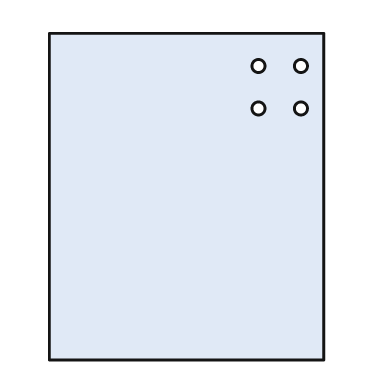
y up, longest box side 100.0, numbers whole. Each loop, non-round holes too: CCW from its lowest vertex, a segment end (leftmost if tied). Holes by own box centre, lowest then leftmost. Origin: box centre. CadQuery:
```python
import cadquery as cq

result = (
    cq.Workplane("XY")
    .moveTo(-42.0, -50.0)
    .lineTo(42.0, -50.0)
    .lineTo(42.0, 50.0)
    .lineTo(-42.0, 50.0)
    .close()
    .moveTo(22.0, 27.0)
    .circle(2.0)
    .moveTo(35.0, 27.0)
    .circle(2.0)
    .moveTo(22.0, 40.0)
    .circle(2.0)
    .moveTo(35.0, 40.0)
    .circle(2.0)
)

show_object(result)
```